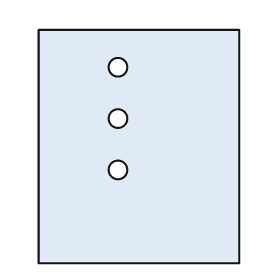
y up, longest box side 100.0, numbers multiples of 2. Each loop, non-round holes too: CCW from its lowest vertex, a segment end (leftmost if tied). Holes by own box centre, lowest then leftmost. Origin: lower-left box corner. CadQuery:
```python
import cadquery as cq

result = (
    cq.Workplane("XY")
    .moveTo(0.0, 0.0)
    .lineTo(86.0, 0.0)
    .lineTo(86.0, 100.0)
    .lineTo(0.0, 100.0)
    .close()
    .moveTo(34.0, 40.0)
    .circle(4.0)
    .moveTo(34.0, 62.0)
    .circle(4.0)
    .moveTo(34.0, 84.0)
    .circle(4.0)
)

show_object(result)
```